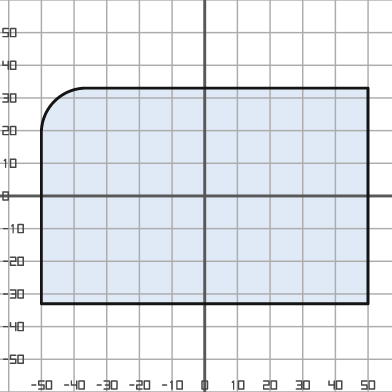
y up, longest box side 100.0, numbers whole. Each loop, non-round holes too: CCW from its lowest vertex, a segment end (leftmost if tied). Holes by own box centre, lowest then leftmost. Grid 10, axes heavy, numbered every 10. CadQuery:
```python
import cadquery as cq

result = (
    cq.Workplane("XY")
    .moveTo(-50.0, -33.0)
    .lineTo(50.0, -33.0)
    .lineTo(50.0, 33.0)
    .lineTo(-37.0, 33.0)
    .threePointArc((-46.0, 29.0), (-50.0, 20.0))
    .close()
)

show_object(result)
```